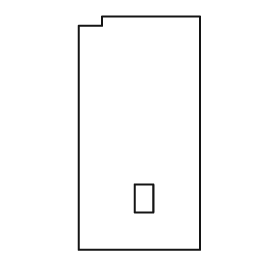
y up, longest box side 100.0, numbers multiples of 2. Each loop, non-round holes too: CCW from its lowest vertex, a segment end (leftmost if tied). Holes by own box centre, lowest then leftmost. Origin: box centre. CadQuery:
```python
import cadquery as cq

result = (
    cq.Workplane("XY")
    .moveTo(-26.0, -50.0)
    .lineTo(26.0, -50.0)
    .lineTo(26.0, 50.0)
    .lineTo(-16.0, 50.0)
    .lineTo(-16.0, 46.0)
    .lineTo(-26.0, 46.0)
    .close()
    .moveTo(-2.0, -34.0)
    .lineTo(6.0, -34.0)
    .lineTo(6.0, -22.0)
    .lineTo(-2.0, -22.0)
    .close()
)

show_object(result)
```